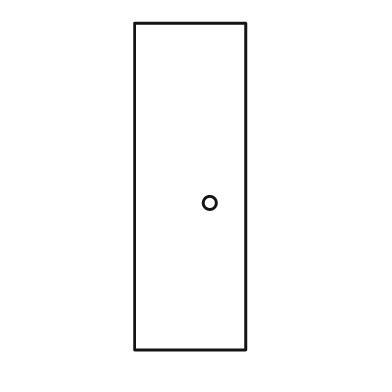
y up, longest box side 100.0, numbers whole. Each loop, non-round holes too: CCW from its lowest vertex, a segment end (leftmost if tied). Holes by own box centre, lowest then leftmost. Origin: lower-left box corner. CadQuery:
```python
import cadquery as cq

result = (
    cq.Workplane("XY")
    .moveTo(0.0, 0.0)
    .lineTo(34.0, 0.0)
    .lineTo(34.0, 100.0)
    .lineTo(0.0, 100.0)
    .close()
    .moveTo(23.0, 45.0)
    .circle(2.0)
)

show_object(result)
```